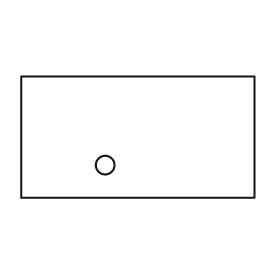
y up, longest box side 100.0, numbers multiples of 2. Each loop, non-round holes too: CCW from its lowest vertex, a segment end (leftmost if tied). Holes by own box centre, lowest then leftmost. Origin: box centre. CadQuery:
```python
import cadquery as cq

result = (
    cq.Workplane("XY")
    .moveTo(-50.0, -26.0)
    .lineTo(50.0, -26.0)
    .lineTo(50.0, 26.0)
    .lineTo(-50.0, 26.0)
    .close()
    .moveTo(-14.0, -12.0)
    .circle(4.0)
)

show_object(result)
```